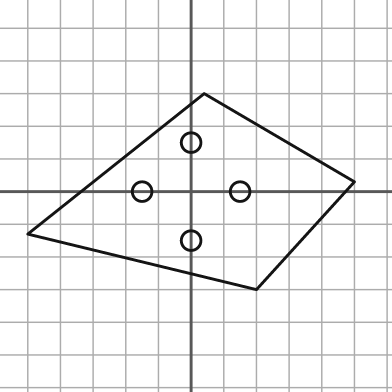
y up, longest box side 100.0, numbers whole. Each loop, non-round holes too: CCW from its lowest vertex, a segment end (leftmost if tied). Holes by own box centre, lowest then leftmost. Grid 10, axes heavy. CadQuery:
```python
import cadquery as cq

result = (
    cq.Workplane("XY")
    .moveTo(20.0, -30.0)
    .lineTo(50.0, 3.0)
    .lineTo(4.0, 30.0)
    .lineTo(-50.0, -13.0)
    .close()
    .moveTo(0.0, -15.0)
    .circle(3.0)
    .moveTo(-15.0, 0.0)
    .circle(3.0)
    .moveTo(15.0, 0.0)
    .circle(3.0)
    .moveTo(0.0, 15.0)
    .circle(3.0)
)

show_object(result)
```